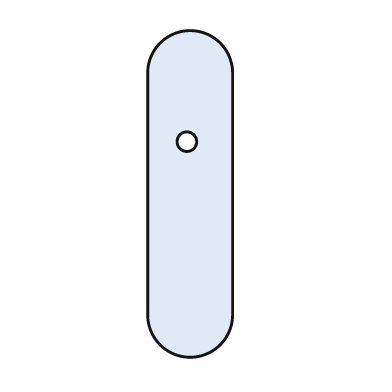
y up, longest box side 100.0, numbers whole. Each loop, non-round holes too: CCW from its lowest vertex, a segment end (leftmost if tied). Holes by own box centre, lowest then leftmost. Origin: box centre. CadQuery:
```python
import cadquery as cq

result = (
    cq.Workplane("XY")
    .moveTo(-13.0, -37.0)
    .threePointArc((0.0, -50.0), (13.0, -37.0))
    .lineTo(13.0, 37.0)
    .threePointArc((0.0, 50.0), (-13.0, 37.0))
    .close()
    .moveTo(-1.0, 16.0)
    .circle(3.0)
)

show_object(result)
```